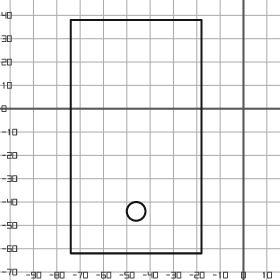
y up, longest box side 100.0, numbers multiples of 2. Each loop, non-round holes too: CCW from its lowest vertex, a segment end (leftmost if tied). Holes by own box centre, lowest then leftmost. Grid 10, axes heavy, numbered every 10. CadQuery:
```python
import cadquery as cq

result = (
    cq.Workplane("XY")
    .moveTo(-74.0, -62.0)
    .lineTo(-18.0, -62.0)
    .lineTo(-18.0, 38.0)
    .lineTo(-74.0, 38.0)
    .close()
    .moveTo(-46.0, -44.0)
    .circle(4.0)
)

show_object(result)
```